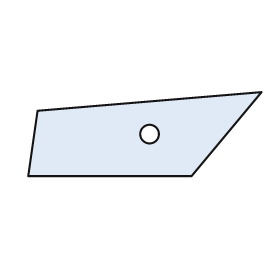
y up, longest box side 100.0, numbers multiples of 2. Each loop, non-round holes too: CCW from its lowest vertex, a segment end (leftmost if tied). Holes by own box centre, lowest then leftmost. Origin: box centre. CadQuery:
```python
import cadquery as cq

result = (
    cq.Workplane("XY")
    .moveTo(-50.0, -18.0)
    .lineTo(20.0, -18.0)
    .lineTo(50.0, 18.0)
    .lineTo(-46.0, 10.0)
    .close()
    .moveTo(2.0, 0.0)
    .circle(4.0)
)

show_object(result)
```